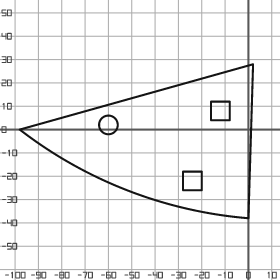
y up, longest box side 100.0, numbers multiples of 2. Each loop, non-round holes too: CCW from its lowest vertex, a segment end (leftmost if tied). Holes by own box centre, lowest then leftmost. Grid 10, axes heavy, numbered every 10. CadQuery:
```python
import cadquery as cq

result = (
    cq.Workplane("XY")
    .moveTo(0.0, -38.0)
    .lineTo(2.0, 28.0)
    .lineTo(-98.0, 0.0)
    .threePointArc((-52.0, -26.0), (0.0, -38.0))
    .close()
    .moveTo(-28.0, -26.0)
    .lineTo(-20.0, -26.0)
    .lineTo(-20.0, -18.0)
    .lineTo(-28.0, -18.0)
    .close()
    .moveTo(-60.0, 2.0)
    .circle(4.0)
    .moveTo(-16.0, 4.0)
    .lineTo(-8.0, 4.0)
    .lineTo(-8.0, 12.0)
    .lineTo(-16.0, 12.0)
    .close()
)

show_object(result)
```